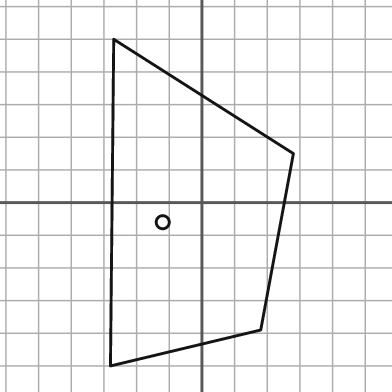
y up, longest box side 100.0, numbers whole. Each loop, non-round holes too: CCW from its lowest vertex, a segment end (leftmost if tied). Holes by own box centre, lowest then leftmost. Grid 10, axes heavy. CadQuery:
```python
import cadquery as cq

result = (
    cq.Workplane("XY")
    .moveTo(-28.0, -50.0)
    .lineTo(18.0, -39.0)
    .lineTo(28.0, 15.0)
    .lineTo(-27.0, 50.0)
    .close()
    .moveTo(-12.0, -6.0)
    .circle(2.0)
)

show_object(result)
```